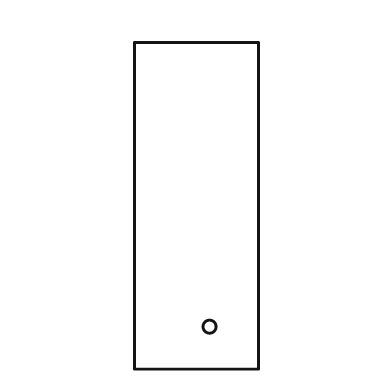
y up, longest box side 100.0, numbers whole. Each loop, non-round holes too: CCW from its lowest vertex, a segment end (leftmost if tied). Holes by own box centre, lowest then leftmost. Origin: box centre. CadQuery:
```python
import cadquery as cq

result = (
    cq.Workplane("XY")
    .moveTo(-19.0, -50.0)
    .lineTo(19.0, -50.0)
    .lineTo(19.0, 50.0)
    .lineTo(-19.0, 50.0)
    .close()
    .moveTo(4.0, -37.0)
    .circle(2.0)
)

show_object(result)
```